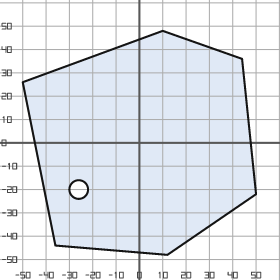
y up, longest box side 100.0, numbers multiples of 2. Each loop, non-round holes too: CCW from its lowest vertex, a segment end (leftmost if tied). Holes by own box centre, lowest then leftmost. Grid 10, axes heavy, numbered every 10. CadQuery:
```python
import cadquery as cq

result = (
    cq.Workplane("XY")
    .moveTo(12.0, -48.0)
    .lineTo(50.0, -22.0)
    .lineTo(44.0, 36.0)
    .lineTo(10.0, 48.0)
    .lineTo(-50.0, 26.0)
    .lineTo(-36.0, -44.0)
    .close()
    .moveTo(-26.0, -20.0)
    .circle(4.0)
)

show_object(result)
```